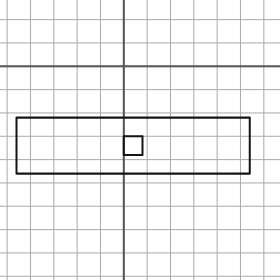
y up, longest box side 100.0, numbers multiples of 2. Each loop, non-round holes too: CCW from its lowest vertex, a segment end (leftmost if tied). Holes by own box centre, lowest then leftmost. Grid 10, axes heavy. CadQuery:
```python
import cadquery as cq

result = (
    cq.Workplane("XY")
    .moveTo(-46.0, -46.0)
    .lineTo(54.0, -46.0)
    .lineTo(54.0, -22.0)
    .lineTo(-46.0, -22.0)
    .close()
    .moveTo(0.0, -38.0)
    .lineTo(8.0, -38.0)
    .lineTo(8.0, -30.0)
    .lineTo(0.0, -30.0)
    .close()
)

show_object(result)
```